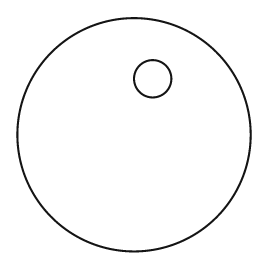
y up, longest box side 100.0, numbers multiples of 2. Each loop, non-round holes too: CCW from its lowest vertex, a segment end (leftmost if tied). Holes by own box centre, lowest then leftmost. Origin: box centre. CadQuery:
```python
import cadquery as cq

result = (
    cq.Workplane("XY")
    .moveTo(0.0, 0.0)
    .circle(50.0)
    .moveTo(8.0, 24.0)
    .circle(8.0)
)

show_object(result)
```